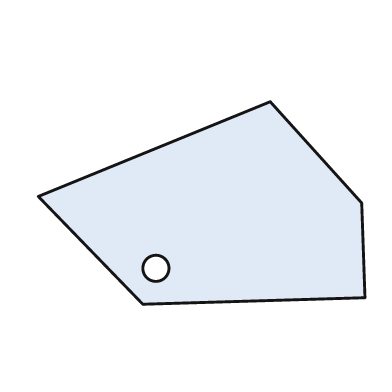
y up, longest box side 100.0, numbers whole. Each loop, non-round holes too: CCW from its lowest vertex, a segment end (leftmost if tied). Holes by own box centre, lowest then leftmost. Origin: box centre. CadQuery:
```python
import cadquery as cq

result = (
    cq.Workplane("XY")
    .moveTo(-18.0, -31.0)
    .lineTo(50.0, -29.0)
    .lineTo(49.0, 0.0)
    .lineTo(21.0, 31.0)
    .lineTo(-50.0, 2.0)
    .close()
    .moveTo(-14.0, -20.0)
    .circle(4.0)
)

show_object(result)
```